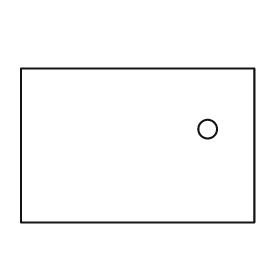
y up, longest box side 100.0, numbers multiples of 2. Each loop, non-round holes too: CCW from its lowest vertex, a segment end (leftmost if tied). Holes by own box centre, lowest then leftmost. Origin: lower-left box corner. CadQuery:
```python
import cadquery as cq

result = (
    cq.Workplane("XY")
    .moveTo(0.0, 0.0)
    .lineTo(100.0, 0.0)
    .lineTo(100.0, 66.0)
    .lineTo(0.0, 66.0)
    .close()
    .moveTo(80.0, 40.0)
    .circle(4.0)
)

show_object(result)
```